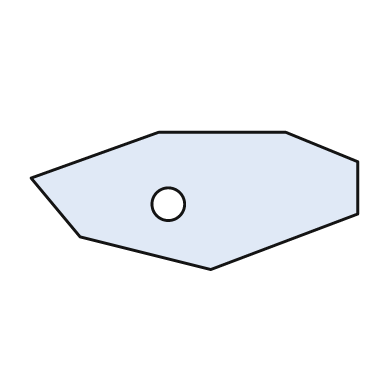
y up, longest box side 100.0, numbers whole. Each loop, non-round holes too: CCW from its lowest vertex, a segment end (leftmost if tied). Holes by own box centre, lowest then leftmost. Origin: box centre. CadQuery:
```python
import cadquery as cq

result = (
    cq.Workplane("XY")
    .moveTo(5.0, -21.0)
    .lineTo(50.0, -4.0)
    .lineTo(50.0, 12.0)
    .lineTo(28.0, 21.0)
    .lineTo(-11.0, 21.0)
    .lineTo(-50.0, 7.0)
    .lineTo(-35.0, -11.0)
    .close()
    .moveTo(-8.0, -1.0)
    .circle(5.0)
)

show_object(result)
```